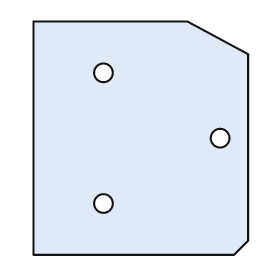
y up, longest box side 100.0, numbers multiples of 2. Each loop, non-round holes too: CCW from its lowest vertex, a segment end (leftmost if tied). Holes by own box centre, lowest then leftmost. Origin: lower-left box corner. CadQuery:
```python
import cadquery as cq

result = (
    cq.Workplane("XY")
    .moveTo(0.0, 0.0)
    .lineTo(86.0, 0.0)
    .lineTo(92.0, 6.0)
    .lineTo(92.0, 86.0)
    .lineTo(66.0, 100.0)
    .lineTo(0.0, 100.0)
    .close()
    .moveTo(30.0, 22.0)
    .circle(4.0)
    .moveTo(80.0, 50.0)
    .circle(4.0)
    .moveTo(30.0, 78.0)
    .circle(4.0)
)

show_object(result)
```